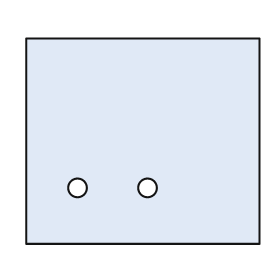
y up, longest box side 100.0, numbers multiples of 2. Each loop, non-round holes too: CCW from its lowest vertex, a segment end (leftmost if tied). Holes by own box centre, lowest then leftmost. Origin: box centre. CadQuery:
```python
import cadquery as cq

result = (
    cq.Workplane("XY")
    .moveTo(-50.0, -44.0)
    .lineTo(50.0, -44.0)
    .lineTo(50.0, 44.0)
    .lineTo(-50.0, 44.0)
    .close()
    .moveTo(-28.0, -20.0)
    .circle(4.0)
    .moveTo(2.0, -20.0)
    .circle(4.0)
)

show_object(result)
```